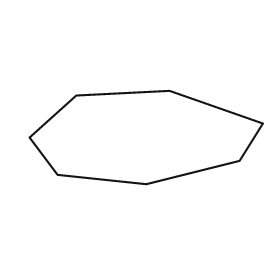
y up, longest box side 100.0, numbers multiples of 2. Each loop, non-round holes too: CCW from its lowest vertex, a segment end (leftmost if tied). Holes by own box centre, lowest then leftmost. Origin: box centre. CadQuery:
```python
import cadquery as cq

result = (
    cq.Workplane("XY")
    .moveTo(0.0, -20.0)
    .lineTo(40.0, -10.0)
    .lineTo(50.0, 6.0)
    .lineTo(10.0, 20.0)
    .lineTo(-30.0, 18.0)
    .lineTo(-50.0, 0.0)
    .lineTo(-38.0, -16.0)
    .close()
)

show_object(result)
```